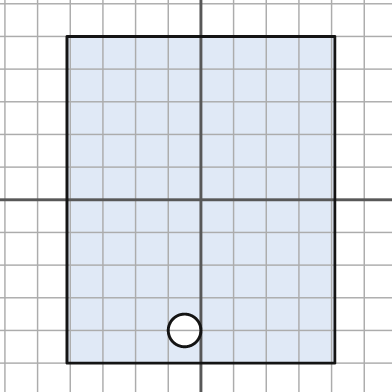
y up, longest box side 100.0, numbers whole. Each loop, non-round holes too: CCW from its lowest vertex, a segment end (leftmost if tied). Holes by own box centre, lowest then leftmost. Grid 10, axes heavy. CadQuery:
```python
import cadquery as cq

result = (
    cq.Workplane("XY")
    .moveTo(-41.0, -50.0)
    .lineTo(41.0, -50.0)
    .lineTo(41.0, 50.0)
    .lineTo(-41.0, 50.0)
    .close()
    .moveTo(-5.0, -40.0)
    .circle(5.0)
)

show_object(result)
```